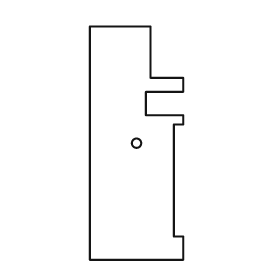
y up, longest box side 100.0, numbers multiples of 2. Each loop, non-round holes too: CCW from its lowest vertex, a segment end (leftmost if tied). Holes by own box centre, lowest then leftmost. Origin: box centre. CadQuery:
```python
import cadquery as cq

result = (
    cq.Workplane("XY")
    .moveTo(-20.0, -50.0)
    .lineTo(20.0, -50.0)
    .lineTo(20.0, -40.0)
    .lineTo(16.0, -40.0)
    .lineTo(16.0, 8.0)
    .lineTo(20.0, 8.0)
    .lineTo(20.0, 12.0)
    .lineTo(4.0, 12.0)
    .lineTo(4.0, 22.0)
    .lineTo(20.0, 22.0)
    .lineTo(20.0, 28.0)
    .lineTo(6.0, 28.0)
    .lineTo(6.0, 50.0)
    .lineTo(-20.0, 50.0)
    .close()
    .moveTo(0.0, 0.0)
    .circle(2.0)
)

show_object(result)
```